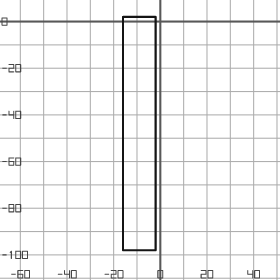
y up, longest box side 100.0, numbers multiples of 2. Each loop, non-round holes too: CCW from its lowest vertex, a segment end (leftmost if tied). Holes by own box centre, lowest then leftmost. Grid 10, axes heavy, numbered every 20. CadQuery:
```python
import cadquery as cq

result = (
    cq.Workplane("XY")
    .moveTo(-16.0, -98.0)
    .lineTo(-2.0, -98.0)
    .lineTo(-2.0, 2.0)
    .lineTo(-16.0, 2.0)
    .close()
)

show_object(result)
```